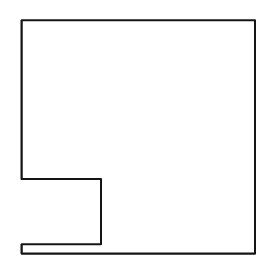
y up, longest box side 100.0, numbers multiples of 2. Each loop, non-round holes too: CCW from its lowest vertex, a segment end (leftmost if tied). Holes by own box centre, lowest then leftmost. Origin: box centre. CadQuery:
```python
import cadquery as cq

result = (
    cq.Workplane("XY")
    .moveTo(-50.0, -50.0)
    .lineTo(50.0, -50.0)
    .lineTo(50.0, 50.0)
    .lineTo(-50.0, 50.0)
    .lineTo(-50.0, -18.0)
    .lineTo(-16.0, -18.0)
    .lineTo(-16.0, -46.0)
    .lineTo(-50.0, -46.0)
    .close()
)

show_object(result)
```